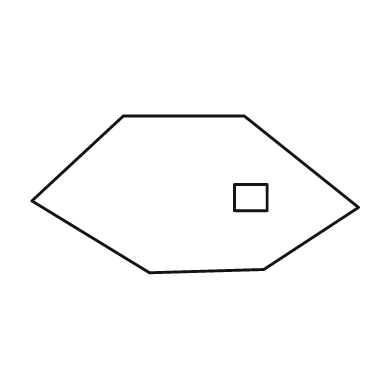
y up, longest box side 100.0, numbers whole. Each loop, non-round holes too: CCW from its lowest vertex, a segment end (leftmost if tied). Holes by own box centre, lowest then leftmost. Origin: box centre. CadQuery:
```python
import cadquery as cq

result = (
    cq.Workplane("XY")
    .moveTo(-14.0, -24.0)
    .lineTo(21.0, -23.0)
    .lineTo(50.0, -4.0)
    .lineTo(15.0, 24.0)
    .lineTo(-22.0, 24.0)
    .lineTo(-50.0, -2.0)
    .close()
    .moveTo(12.0, -5.0)
    .lineTo(22.0, -5.0)
    .lineTo(22.0, 3.0)
    .lineTo(12.0, 3.0)
    .close()
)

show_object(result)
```